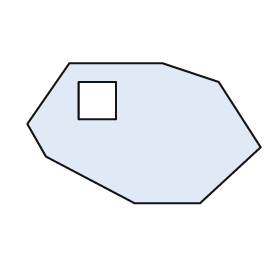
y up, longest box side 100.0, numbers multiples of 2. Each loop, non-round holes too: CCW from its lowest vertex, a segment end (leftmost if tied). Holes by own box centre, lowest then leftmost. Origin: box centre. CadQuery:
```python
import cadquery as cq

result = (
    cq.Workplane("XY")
    .moveTo(-4.0, -30.0)
    .lineTo(24.0, -30.0)
    .lineTo(50.0, -6.0)
    .lineTo(32.0, 22.0)
    .lineTo(8.0, 30.0)
    .lineTo(-32.0, 30.0)
    .lineTo(-50.0, 4.0)
    .lineTo(-42.0, -10.0)
    .close()
    .moveTo(-28.0, 6.0)
    .lineTo(-12.0, 6.0)
    .lineTo(-12.0, 22.0)
    .lineTo(-28.0, 22.0)
    .close()
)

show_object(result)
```